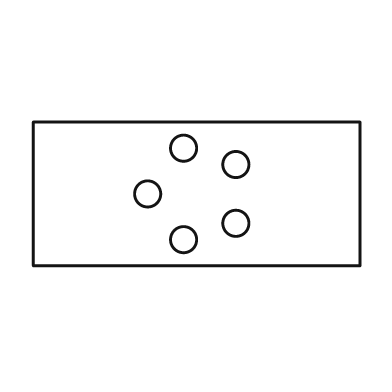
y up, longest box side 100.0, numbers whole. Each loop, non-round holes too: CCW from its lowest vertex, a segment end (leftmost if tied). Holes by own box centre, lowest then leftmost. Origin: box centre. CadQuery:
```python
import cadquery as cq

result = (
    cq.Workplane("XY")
    .moveTo(-50.0, -22.0)
    .lineTo(50.0, -22.0)
    .lineTo(50.0, 22.0)
    .lineTo(-50.0, 22.0)
    .close()
    .moveTo(-4.0, -14.0)
    .circle(4.0)
    .moveTo(12.0, -9.0)
    .circle(4.0)
    .moveTo(-15.0, 0.0)
    .circle(4.0)
    .moveTo(12.0, 9.0)
    .circle(4.0)
    .moveTo(-4.0, 14.0)
    .circle(4.0)
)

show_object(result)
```